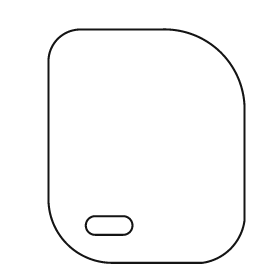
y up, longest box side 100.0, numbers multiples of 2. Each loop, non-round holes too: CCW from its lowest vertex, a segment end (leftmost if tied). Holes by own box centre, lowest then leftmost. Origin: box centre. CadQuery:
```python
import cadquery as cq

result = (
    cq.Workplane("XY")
    .moveTo(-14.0, -50.0)
    .lineTo(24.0, -50.0)
    .threePointArc((36.0, -44.0), (42.0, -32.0))
    .lineTo(42.0, 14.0)
    .threePointArc((32.0, 40.0), (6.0, 50.0))
    .lineTo(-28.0, 50.0)
    .threePointArc((-38.0, 46.0), (-42.0, 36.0))
    .lineTo(-42.0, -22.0)
    .threePointArc((-34.0, -42.0), (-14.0, -50.0))
    .close()
    .moveTo(-22.0, -38.0)
    .lineTo(-10.0, -38.0)
    .threePointArc((-6.0, -34.0), (-10.0, -30.0))
    .lineTo(-22.0, -30.0)
    .threePointArc((-26.0, -34.0), (-22.0, -38.0))
    .close()
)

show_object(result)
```